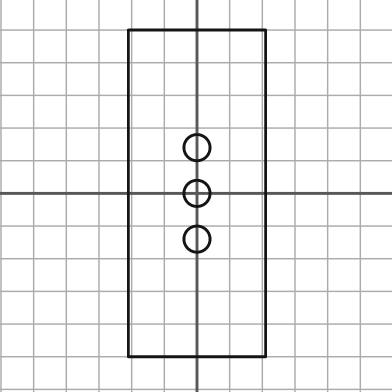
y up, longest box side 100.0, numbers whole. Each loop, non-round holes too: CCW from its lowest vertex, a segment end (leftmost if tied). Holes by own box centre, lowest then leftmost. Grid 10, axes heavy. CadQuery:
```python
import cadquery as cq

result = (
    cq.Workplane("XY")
    .moveTo(-21.0, -50.0)
    .lineTo(21.0, -50.0)
    .lineTo(21.0, 50.0)
    .lineTo(-21.0, 50.0)
    .close()
    .moveTo(0.0, -14.0)
    .circle(4.0)
    .moveTo(0.0, 0.0)
    .circle(4.0)
    .moveTo(0.0, 14.0)
    .circle(4.0)
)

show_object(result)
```